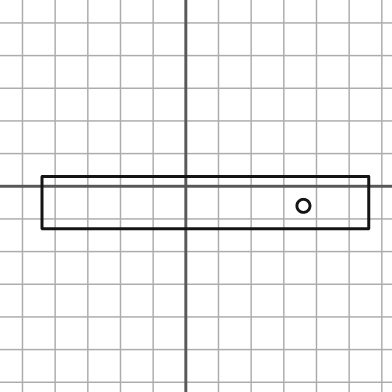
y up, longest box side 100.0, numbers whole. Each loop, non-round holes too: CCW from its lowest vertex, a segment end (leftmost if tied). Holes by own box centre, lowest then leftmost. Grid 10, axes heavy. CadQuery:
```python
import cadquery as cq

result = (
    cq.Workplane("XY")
    .moveTo(-44.0, -13.0)
    .lineTo(56.0, -13.0)
    .lineTo(56.0, 3.0)
    .lineTo(-44.0, 3.0)
    .close()
    .moveTo(36.0, -6.0)
    .circle(2.0)
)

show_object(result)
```